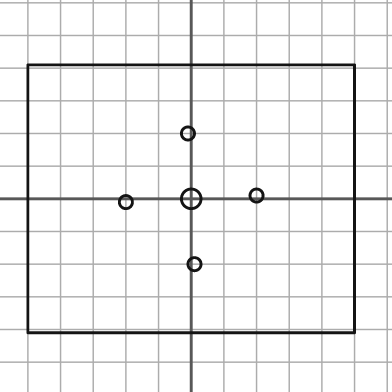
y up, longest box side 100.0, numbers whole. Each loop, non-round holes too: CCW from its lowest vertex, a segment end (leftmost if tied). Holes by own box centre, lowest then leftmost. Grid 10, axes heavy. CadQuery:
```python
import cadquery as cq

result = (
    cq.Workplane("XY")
    .moveTo(-50.0, -41.0)
    .lineTo(50.0, -41.0)
    .lineTo(50.0, 41.0)
    .lineTo(-50.0, 41.0)
    .close()
    .moveTo(1.0, -20.0)
    .circle(2.0)
    .moveTo(-20.0, -1.0)
    .circle(2.0)
    .moveTo(0.0, 0.0)
    .circle(3.0)
    .moveTo(20.0, 1.0)
    .circle(2.0)
    .moveTo(-1.0, 20.0)
    .circle(2.0)
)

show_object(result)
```